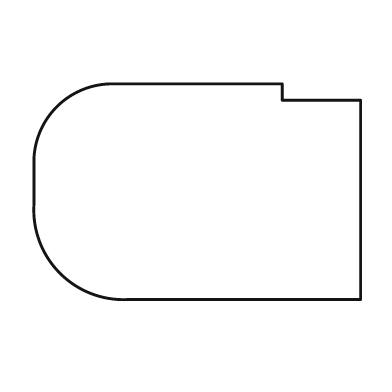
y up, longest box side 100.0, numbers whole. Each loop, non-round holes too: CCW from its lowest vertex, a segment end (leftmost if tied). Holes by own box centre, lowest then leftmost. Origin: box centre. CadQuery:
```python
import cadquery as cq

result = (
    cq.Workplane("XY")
    .moveTo(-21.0, -33.0)
    .lineTo(50.0, -33.0)
    .lineTo(50.0, 28.0)
    .lineTo(26.0, 28.0)
    .lineTo(26.0, 33.0)
    .lineTo(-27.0, 33.0)
    .threePointArc((-43.0, 26.0), (-50.0, 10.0))
    .lineTo(-50.0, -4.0)
    .threePointArc((-42.0, -25.0), (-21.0, -33.0))
    .close()
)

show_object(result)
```